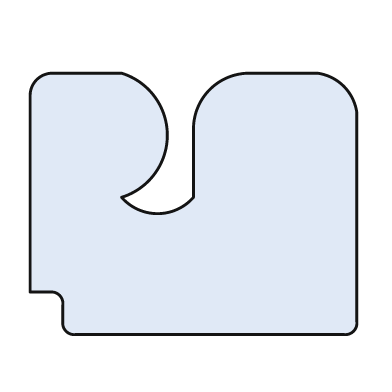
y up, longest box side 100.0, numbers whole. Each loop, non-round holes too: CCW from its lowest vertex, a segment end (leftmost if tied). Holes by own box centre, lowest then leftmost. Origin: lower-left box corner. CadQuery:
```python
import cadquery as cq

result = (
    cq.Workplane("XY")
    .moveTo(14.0, 0.0)
    .lineTo(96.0, 0.0)
    .threePointArc((99.0, 1.0), (100.0, 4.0))
    .lineTo(100.0, 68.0)
    .threePointArc((96.0, 76.0), (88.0, 80.0))
    .lineTo(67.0, 80.0)
    .threePointArc((55.0, 75.0), (50.0, 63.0))
    .lineTo(50.0, 42.0)
    .threePointArc((39.0, 37.0), (28.0, 42.0))
    .threePointArc((42.0, 61.0), (28.0, 80.0))
    .lineTo(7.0, 80.0)
    .threePointArc((2.0, 78.0), (0.0, 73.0))
    .lineTo(0.0, 13.0)
    .lineTo(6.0, 13.0)
    .threePointArc((9.0, 12.0), (10.0, 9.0))
    .lineTo(10.0, 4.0)
    .threePointArc((11.0, 1.0), (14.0, 0.0))
    .close()
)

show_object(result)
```